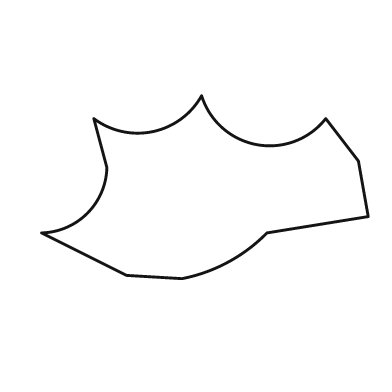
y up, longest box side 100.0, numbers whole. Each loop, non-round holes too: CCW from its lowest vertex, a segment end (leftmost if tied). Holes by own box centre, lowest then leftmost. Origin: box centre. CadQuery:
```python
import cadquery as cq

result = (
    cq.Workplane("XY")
    .moveTo(-7.0, -28.0)
    .threePointArc((7.0, -23.0), (19.0, -14.0))
    .lineTo(50.0, -9.0)
    .lineTo(47.0, 8.0)
    .lineTo(37.0, 21.0)
    .threePointArc((16.0, 13.0), (-1.0, 28.0))
    .threePointArc((-16.0, 17.0), (-34.0, 21.0))
    .lineTo(-30.0, 6.0)
    .threePointArc((-36.0, -8.0), (-50.0, -14.0))
    .lineTo(-24.0, -27.0)
    .close()
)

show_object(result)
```